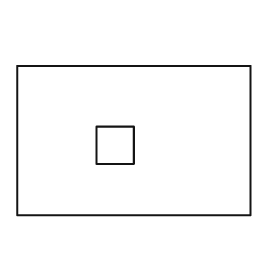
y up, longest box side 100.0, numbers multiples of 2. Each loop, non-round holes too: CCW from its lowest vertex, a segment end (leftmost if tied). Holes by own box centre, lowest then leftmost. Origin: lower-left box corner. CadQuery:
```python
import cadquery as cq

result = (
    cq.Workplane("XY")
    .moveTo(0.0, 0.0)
    .lineTo(100.0, 0.0)
    .lineTo(100.0, 64.0)
    .lineTo(0.0, 64.0)
    .close()
    .moveTo(34.0, 22.0)
    .lineTo(50.0, 22.0)
    .lineTo(50.0, 38.0)
    .lineTo(34.0, 38.0)
    .close()
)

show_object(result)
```